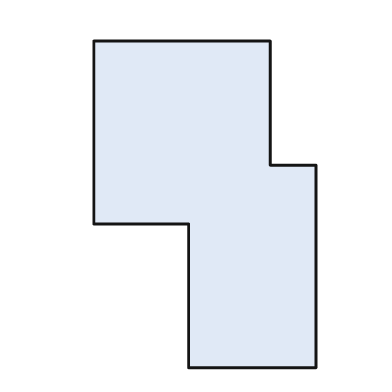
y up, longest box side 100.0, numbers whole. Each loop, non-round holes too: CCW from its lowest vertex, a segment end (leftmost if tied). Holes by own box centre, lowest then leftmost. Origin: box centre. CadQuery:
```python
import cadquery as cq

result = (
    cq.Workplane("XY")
    .moveTo(-5.0, -50.0)
    .lineTo(34.0, -50.0)
    .lineTo(34.0, 12.0)
    .lineTo(20.0, 12.0)
    .lineTo(20.0, 50.0)
    .lineTo(-34.0, 50.0)
    .lineTo(-34.0, -6.0)
    .lineTo(-5.0, -6.0)
    .close()
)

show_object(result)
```